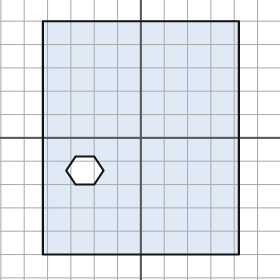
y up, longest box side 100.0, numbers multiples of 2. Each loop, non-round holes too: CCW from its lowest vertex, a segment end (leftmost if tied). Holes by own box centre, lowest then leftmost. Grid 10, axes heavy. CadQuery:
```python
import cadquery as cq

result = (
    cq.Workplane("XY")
    .moveTo(-42.0, -50.0)
    .lineTo(42.0, -50.0)
    .lineTo(42.0, 50.0)
    .lineTo(-42.0, 50.0)
    .close()
    .moveTo(-28.0, -20.0)
    .lineTo(-20.0, -20.0)
    .lineTo(-16.0, -14.0)
    .lineTo(-20.0, -8.0)
    .lineTo(-28.0, -8.0)
    .lineTo(-32.0, -14.0)
    .close()
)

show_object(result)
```